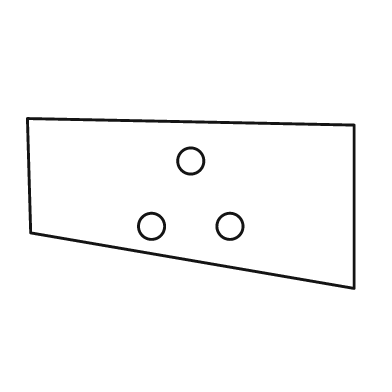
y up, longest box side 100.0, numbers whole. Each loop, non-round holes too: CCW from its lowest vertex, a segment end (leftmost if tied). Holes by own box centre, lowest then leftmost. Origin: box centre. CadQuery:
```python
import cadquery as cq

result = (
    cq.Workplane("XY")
    .moveTo(50.0, -26.0)
    .lineTo(50.0, 24.0)
    .lineTo(-50.0, 26.0)
    .lineTo(-49.0, -9.0)
    .close()
    .moveTo(-12.0, -7.0)
    .circle(4.0)
    .moveTo(12.0, -7.0)
    .circle(4.0)
    .moveTo(0.0, 13.0)
    .circle(4.0)
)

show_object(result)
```